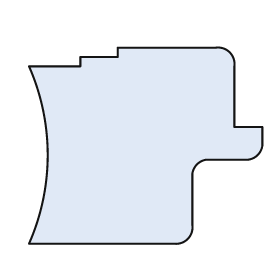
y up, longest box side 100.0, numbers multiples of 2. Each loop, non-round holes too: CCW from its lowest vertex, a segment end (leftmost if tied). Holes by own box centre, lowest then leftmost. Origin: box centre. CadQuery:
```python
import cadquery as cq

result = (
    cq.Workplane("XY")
    .moveTo(-50.0, -42.0)
    .lineTo(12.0, -42.0)
    .threePointArc((18.0, -40.0), (20.0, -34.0))
    .lineTo(20.0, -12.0)
    .threePointArc((22.0, -8.0), (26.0, -6.0))
    .lineTo(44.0, -6.0)
    .threePointArc((48.0, -4.0), (50.0, 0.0))
    .lineTo(50.0, 8.0)
    .lineTo(38.0, 8.0)
    .lineTo(38.0, 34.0)
    .threePointArc((36.0, 40.0), (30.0, 42.0))
    .lineTo(-12.0, 42.0)
    .lineTo(-12.0, 38.0)
    .lineTo(-28.0, 38.0)
    .lineTo(-28.0, 34.0)
    .lineTo(-50.0, 34.0)
    .threePointArc((-42.0, -4.0), (-50.0, -42.0))
    .close()
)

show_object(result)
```